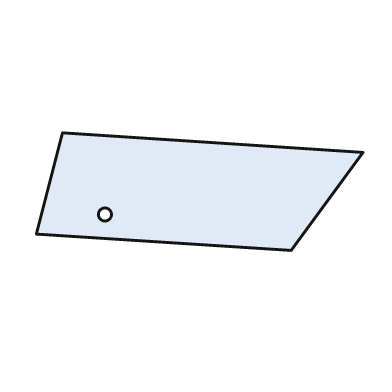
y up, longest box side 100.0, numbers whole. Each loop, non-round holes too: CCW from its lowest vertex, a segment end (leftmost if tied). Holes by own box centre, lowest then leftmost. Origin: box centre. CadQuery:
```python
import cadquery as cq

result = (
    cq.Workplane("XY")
    .moveTo(28.0, -18.0)
    .lineTo(50.0, 12.0)
    .lineTo(-42.0, 18.0)
    .lineTo(-50.0, -13.0)
    .close()
    .moveTo(-29.0, -7.0)
    .circle(2.0)
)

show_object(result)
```